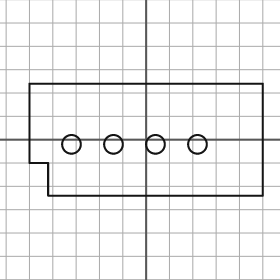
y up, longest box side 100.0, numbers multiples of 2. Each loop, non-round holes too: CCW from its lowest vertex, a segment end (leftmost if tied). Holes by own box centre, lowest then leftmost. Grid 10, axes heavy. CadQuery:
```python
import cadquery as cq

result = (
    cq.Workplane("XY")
    .moveTo(-42.0, -24.0)
    .lineTo(50.0, -24.0)
    .lineTo(50.0, 24.0)
    .lineTo(-50.0, 24.0)
    .lineTo(-50.0, -10.0)
    .lineTo(-42.0, -10.0)
    .close()
    .moveTo(-32.0, -2.0)
    .circle(4.0)
    .moveTo(-14.0, -2.0)
    .circle(4.0)
    .moveTo(4.0, -2.0)
    .circle(4.0)
    .moveTo(22.0, -2.0)
    .circle(4.0)
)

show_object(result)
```